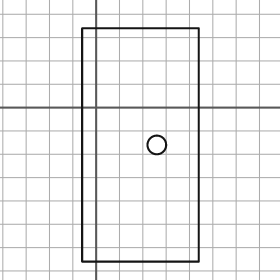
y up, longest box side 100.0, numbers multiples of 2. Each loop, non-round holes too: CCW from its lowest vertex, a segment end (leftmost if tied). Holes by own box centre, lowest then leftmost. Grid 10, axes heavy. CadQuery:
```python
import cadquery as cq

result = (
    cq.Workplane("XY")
    .moveTo(-6.0, -66.0)
    .lineTo(44.0, -66.0)
    .lineTo(44.0, 34.0)
    .lineTo(-6.0, 34.0)
    .close()
    .moveTo(26.0, -16.0)
    .circle(4.0)
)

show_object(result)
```